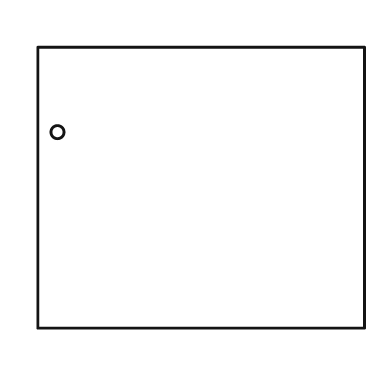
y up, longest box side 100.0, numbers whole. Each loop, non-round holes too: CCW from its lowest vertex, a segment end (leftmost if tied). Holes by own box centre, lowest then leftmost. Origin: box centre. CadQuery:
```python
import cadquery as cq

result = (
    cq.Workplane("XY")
    .moveTo(-50.0, -43.0)
    .lineTo(50.0, -43.0)
    .lineTo(50.0, 43.0)
    .lineTo(-50.0, 43.0)
    .close()
    .moveTo(-44.0, 17.0)
    .circle(2.0)
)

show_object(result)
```